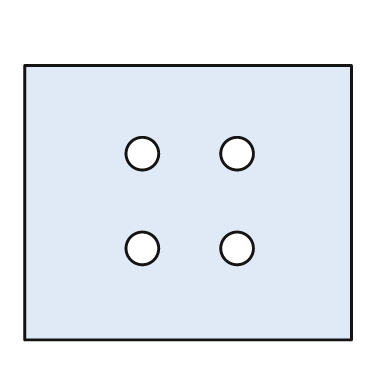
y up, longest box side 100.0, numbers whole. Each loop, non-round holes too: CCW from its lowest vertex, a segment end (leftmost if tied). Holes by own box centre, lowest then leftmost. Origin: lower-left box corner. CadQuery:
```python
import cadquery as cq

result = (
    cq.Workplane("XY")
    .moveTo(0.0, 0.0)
    .lineTo(100.0, 0.0)
    .lineTo(100.0, 84.0)
    .lineTo(0.0, 84.0)
    .close()
    .moveTo(36.0, 28.0)
    .circle(5.0)
    .moveTo(65.0, 28.0)
    .circle(5.0)
    .moveTo(36.0, 57.0)
    .circle(5.0)
    .moveTo(65.0, 57.0)
    .circle(5.0)
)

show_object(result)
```